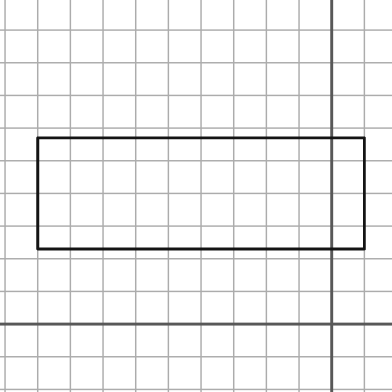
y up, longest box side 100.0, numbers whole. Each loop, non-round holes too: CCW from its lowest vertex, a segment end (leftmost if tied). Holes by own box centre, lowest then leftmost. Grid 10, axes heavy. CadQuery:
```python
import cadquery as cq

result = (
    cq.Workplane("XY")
    .moveTo(-90.0, 23.0)
    .lineTo(10.0, 23.0)
    .lineTo(10.0, 57.0)
    .lineTo(-90.0, 57.0)
    .close()
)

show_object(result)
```